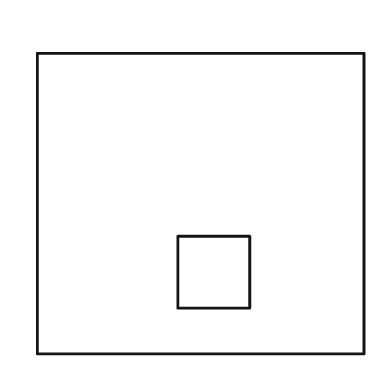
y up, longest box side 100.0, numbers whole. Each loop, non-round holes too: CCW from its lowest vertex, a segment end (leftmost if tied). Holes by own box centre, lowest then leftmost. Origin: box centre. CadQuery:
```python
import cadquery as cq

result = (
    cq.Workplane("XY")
    .moveTo(-50.0, -46.0)
    .lineTo(50.0, -46.0)
    .lineTo(50.0, 46.0)
    .lineTo(-50.0, 46.0)
    .close()
    .moveTo(-7.0, -32.0)
    .lineTo(15.0, -32.0)
    .lineTo(15.0, -10.0)
    .lineTo(-7.0, -10.0)
    .close()
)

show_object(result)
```